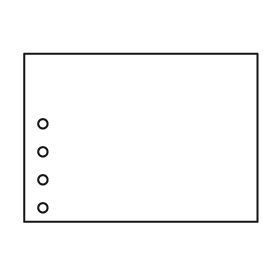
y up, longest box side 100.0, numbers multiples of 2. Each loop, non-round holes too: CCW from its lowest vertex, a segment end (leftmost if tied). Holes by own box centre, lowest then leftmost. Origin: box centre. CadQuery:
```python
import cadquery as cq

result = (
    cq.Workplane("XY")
    .moveTo(-50.0, -36.0)
    .lineTo(50.0, -36.0)
    .lineTo(50.0, 36.0)
    .lineTo(-50.0, 36.0)
    .close()
    .moveTo(-42.0, -30.0)
    .circle(2.0)
    .moveTo(-42.0, -18.0)
    .circle(2.0)
    .moveTo(-42.0, -6.0)
    .circle(2.0)
    .moveTo(-42.0, 6.0)
    .circle(2.0)
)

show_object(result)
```